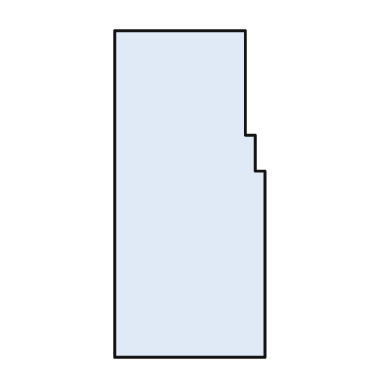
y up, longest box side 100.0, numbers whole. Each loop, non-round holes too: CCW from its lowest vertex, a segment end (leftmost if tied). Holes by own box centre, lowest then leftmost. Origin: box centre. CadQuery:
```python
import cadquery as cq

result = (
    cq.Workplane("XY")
    .moveTo(-23.0, -50.0)
    .lineTo(23.0, -50.0)
    .lineTo(23.0, 7.0)
    .lineTo(20.0, 7.0)
    .lineTo(20.0, 18.0)
    .lineTo(17.0, 18.0)
    .lineTo(17.0, 50.0)
    .lineTo(-23.0, 50.0)
    .close()
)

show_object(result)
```